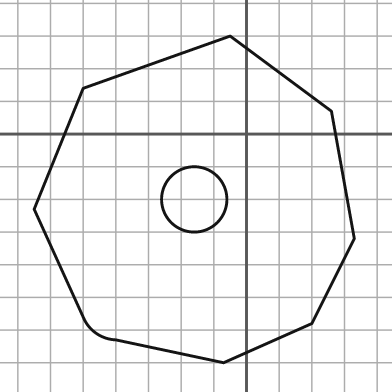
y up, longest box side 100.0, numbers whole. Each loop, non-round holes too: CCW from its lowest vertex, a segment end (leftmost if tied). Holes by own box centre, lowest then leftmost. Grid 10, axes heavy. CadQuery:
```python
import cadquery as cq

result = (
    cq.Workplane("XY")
    .moveTo(-7.0, -70.0)
    .lineTo(20.0, -58.0)
    .lineTo(33.0, -32.0)
    .lineTo(26.0, 7.0)
    .lineTo(-5.0, 30.0)
    .lineTo(-50.0, 14.0)
    .lineTo(-65.0, -23.0)
    .lineTo(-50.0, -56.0)
    .threePointArc((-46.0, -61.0), (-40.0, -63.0))
    .close()
    .moveTo(-16.0, -20.0)
    .circle(10.0)
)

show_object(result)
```